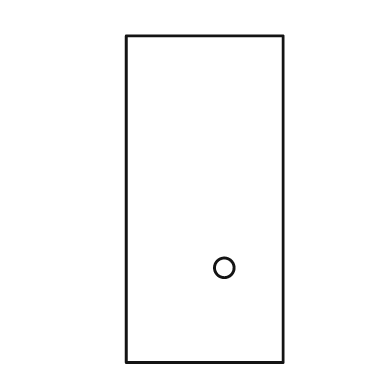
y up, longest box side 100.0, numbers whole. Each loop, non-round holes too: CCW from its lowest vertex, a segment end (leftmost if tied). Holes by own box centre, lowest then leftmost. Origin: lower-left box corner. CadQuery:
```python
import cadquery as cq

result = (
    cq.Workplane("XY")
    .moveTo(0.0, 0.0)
    .lineTo(48.0, 0.0)
    .lineTo(48.0, 100.0)
    .lineTo(0.0, 100.0)
    .close()
    .moveTo(30.0, 29.0)
    .circle(3.0)
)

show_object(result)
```